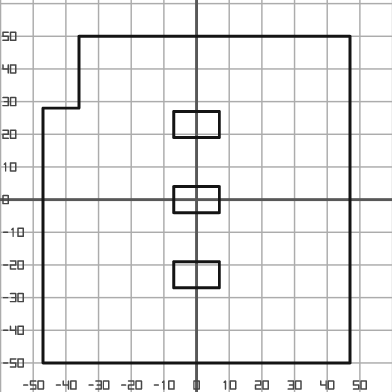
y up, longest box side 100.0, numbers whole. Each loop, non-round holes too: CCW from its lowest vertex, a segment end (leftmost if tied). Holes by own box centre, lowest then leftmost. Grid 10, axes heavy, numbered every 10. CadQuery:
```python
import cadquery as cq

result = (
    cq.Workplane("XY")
    .moveTo(-47.0, -50.0)
    .lineTo(47.0, -50.0)
    .lineTo(47.0, 50.0)
    .lineTo(-36.0, 50.0)
    .lineTo(-36.0, 28.0)
    .lineTo(-47.0, 28.0)
    .close()
    .moveTo(-7.0, -27.0)
    .lineTo(7.0, -27.0)
    .lineTo(7.0, -19.0)
    .lineTo(-7.0, -19.0)
    .close()
    .moveTo(-7.0, -4.0)
    .lineTo(7.0, -4.0)
    .lineTo(7.0, 4.0)
    .lineTo(-7.0, 4.0)
    .close()
    .moveTo(-7.0, 19.0)
    .lineTo(7.0, 19.0)
    .lineTo(7.0, 27.0)
    .lineTo(-7.0, 27.0)
    .close()
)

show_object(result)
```